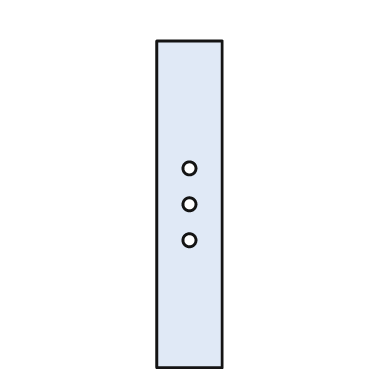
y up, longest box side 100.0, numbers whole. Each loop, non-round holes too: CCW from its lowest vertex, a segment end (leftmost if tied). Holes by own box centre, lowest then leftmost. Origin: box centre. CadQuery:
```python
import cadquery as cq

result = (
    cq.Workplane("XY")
    .moveTo(-10.0, -50.0)
    .lineTo(10.0, -50.0)
    .lineTo(10.0, 50.0)
    .lineTo(-10.0, 50.0)
    .close()
    .moveTo(0.0, -11.0)
    .circle(2.0)
    .moveTo(0.0, 0.0)
    .circle(2.0)
    .moveTo(0.0, 11.0)
    .circle(2.0)
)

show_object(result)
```